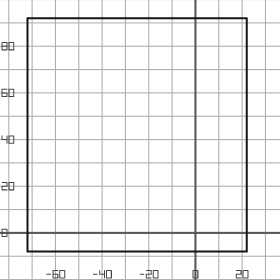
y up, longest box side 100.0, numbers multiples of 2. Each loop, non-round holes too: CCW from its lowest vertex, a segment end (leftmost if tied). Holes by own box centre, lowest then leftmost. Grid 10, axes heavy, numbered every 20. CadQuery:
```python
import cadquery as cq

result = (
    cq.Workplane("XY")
    .moveTo(-72.0, -8.0)
    .lineTo(22.0, -8.0)
    .lineTo(22.0, 92.0)
    .lineTo(-72.0, 92.0)
    .close()
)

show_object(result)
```